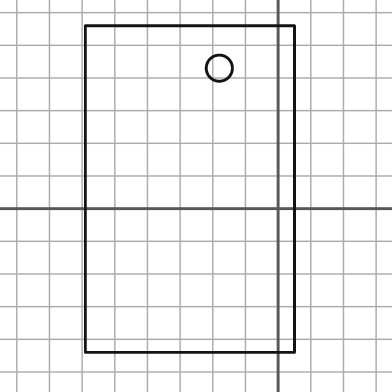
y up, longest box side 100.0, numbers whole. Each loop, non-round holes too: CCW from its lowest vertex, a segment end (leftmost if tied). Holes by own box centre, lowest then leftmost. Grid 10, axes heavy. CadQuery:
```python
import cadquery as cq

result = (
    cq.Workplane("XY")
    .moveTo(-59.0, -44.0)
    .lineTo(5.0, -44.0)
    .lineTo(5.0, 56.0)
    .lineTo(-59.0, 56.0)
    .close()
    .moveTo(-18.0, 43.0)
    .circle(4.0)
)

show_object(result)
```